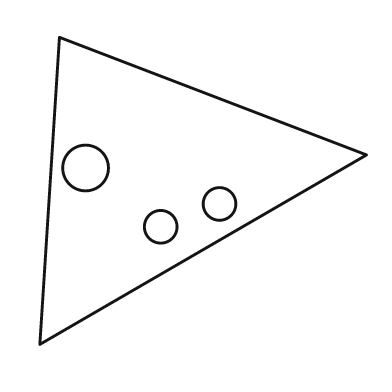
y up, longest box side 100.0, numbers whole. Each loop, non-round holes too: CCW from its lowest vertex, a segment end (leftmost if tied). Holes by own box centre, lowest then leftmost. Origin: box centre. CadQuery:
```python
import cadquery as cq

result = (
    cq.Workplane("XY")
    .moveTo(-50.0, -47.0)
    .lineTo(50.0, 11.0)
    .lineTo(-44.0, 47.0)
    .close()
    .moveTo(-13.0, -11.0)
    .circle(5.0)
    .moveTo(5.0, -4.0)
    .circle(5.0)
    .moveTo(-36.0, 7.0)
    .circle(7.0)
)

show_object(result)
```